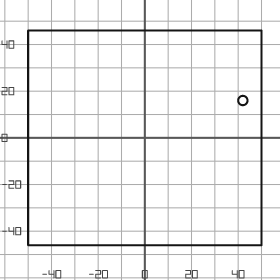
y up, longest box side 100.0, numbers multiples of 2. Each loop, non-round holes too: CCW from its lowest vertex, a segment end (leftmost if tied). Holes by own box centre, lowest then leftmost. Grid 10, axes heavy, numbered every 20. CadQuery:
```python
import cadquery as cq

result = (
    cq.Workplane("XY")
    .moveTo(-50.0, -46.0)
    .lineTo(50.0, -46.0)
    .lineTo(50.0, 46.0)
    .lineTo(-50.0, 46.0)
    .close()
    .moveTo(42.0, 16.0)
    .circle(2.0)
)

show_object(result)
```